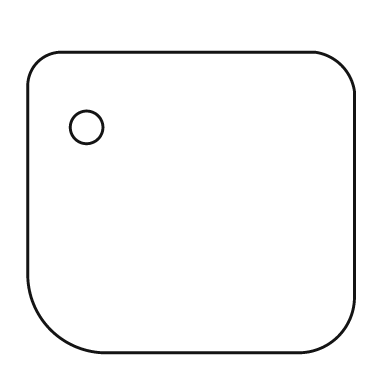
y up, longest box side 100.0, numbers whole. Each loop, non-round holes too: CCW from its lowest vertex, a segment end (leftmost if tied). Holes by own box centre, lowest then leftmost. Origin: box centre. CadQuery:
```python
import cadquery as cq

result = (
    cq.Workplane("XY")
    .moveTo(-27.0, -46.0)
    .lineTo(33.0, -46.0)
    .threePointArc((45.0, -41.0), (50.0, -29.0))
    .lineTo(50.0, 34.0)
    .threePointArc((46.0, 42.0), (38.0, 46.0))
    .lineTo(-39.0, 46.0)
    .threePointArc((-47.0, 43.0), (-50.0, 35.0))
    .lineTo(-50.0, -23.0)
    .threePointArc((-43.0, -39.0), (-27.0, -46.0))
    .close()
    .moveTo(-32.0, 23.0)
    .circle(5.0)
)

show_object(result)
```